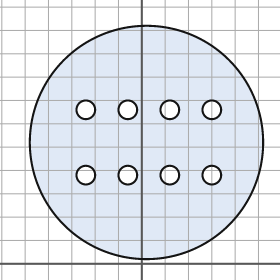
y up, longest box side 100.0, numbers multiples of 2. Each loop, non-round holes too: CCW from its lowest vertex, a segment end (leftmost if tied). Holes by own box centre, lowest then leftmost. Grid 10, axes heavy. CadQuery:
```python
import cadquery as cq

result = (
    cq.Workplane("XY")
    .moveTo(2.0, 52.0)
    .circle(50.0)
    .moveTo(-24.0, 38.0)
    .circle(4.0)
    .moveTo(-6.0, 38.0)
    .circle(4.0)
    .moveTo(12.0, 38.0)
    .circle(4.0)
    .moveTo(30.0, 38.0)
    .circle(4.0)
    .moveTo(-24.0, 66.0)
    .circle(4.0)
    .moveTo(-6.0, 66.0)
    .circle(4.0)
    .moveTo(12.0, 66.0)
    .circle(4.0)
    .moveTo(30.0, 66.0)
    .circle(4.0)
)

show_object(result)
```